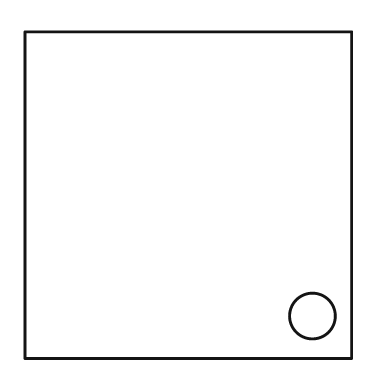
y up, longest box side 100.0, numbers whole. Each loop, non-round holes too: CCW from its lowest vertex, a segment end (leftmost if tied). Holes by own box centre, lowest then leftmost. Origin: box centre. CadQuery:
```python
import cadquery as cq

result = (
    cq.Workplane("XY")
    .moveTo(-50.0, -50.0)
    .lineTo(50.0, -50.0)
    .lineTo(50.0, 50.0)
    .lineTo(-50.0, 50.0)
    .close()
    .moveTo(38.0, -37.0)
    .circle(7.0)
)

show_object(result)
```